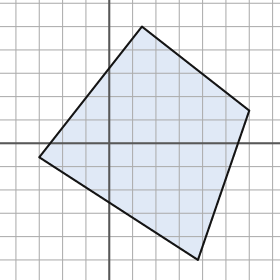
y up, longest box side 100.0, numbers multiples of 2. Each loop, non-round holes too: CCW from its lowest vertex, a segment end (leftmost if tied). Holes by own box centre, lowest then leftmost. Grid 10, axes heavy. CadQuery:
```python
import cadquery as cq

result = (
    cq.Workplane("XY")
    .moveTo(38.0, -50.0)
    .lineTo(60.0, 14.0)
    .lineTo(14.0, 50.0)
    .lineTo(-30.0, -6.0)
    .close()
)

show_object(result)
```